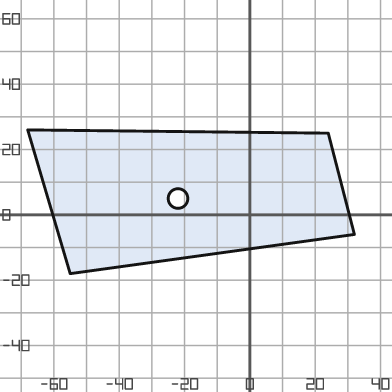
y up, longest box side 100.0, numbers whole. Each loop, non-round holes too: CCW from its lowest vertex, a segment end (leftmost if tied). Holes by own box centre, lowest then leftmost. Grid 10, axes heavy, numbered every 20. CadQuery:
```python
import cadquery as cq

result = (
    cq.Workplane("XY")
    .moveTo(-55.0, -18.0)
    .lineTo(32.0, -6.0)
    .lineTo(24.0, 25.0)
    .lineTo(-68.0, 26.0)
    .close()
    .moveTo(-22.0, 5.0)
    .circle(3.0)
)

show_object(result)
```